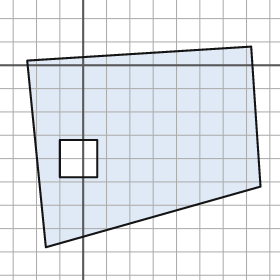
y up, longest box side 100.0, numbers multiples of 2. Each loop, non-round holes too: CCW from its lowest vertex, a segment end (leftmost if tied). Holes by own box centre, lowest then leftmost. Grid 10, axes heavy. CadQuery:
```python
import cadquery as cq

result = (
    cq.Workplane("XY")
    .moveTo(-16.0, -78.0)
    .lineTo(76.0, -52.0)
    .lineTo(72.0, 8.0)
    .lineTo(-24.0, 2.0)
    .close()
    .moveTo(-10.0, -48.0)
    .lineTo(6.0, -48.0)
    .lineTo(6.0, -32.0)
    .lineTo(-10.0, -32.0)
    .close()
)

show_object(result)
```